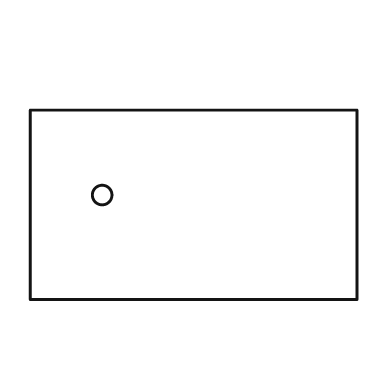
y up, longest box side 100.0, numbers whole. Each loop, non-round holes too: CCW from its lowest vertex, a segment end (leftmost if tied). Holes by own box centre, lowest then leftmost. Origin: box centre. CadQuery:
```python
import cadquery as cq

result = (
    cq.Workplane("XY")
    .moveTo(-50.0, -29.0)
    .lineTo(50.0, -29.0)
    .lineTo(50.0, 29.0)
    .lineTo(-50.0, 29.0)
    .close()
    .moveTo(-28.0, 3.0)
    .circle(3.0)
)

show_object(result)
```